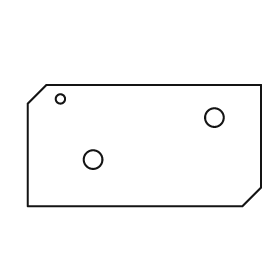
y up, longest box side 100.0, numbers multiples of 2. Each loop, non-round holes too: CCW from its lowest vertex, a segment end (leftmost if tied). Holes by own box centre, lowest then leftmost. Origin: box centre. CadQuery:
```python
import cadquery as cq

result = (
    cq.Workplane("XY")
    .moveTo(-50.0, -26.0)
    .lineTo(42.0, -26.0)
    .lineTo(50.0, -18.0)
    .lineTo(50.0, 26.0)
    .lineTo(-42.0, 26.0)
    .lineTo(-50.0, 18.0)
    .close()
    .moveTo(-22.0, -6.0)
    .circle(4.0)
    .moveTo(30.0, 12.0)
    .circle(4.0)
    .moveTo(-36.0, 20.0)
    .circle(2.0)
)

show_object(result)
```